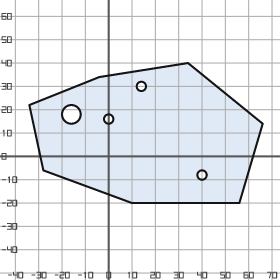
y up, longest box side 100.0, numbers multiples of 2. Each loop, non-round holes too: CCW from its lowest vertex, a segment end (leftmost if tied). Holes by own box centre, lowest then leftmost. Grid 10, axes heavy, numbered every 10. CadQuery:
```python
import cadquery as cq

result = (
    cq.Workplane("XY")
    .moveTo(10.0, -20.0)
    .lineTo(56.0, -20.0)
    .lineTo(66.0, 14.0)
    .lineTo(34.0, 40.0)
    .lineTo(-4.0, 34.0)
    .lineTo(-34.0, 22.0)
    .lineTo(-28.0, -6.0)
    .close()
    .moveTo(40.0, -8.0)
    .circle(2.0)
    .moveTo(0.0, 16.0)
    .circle(2.0)
    .moveTo(-16.0, 18.0)
    .circle(4.0)
    .moveTo(14.0, 30.0)
    .circle(2.0)
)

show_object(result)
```